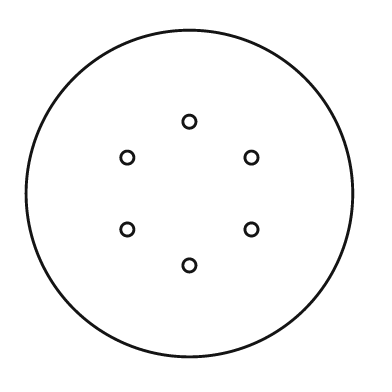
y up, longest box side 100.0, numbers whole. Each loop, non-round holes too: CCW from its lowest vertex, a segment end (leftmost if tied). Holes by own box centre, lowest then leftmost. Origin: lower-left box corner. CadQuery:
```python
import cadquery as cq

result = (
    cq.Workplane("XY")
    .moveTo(50.0, 50.0)
    .circle(50.0)
    .moveTo(50.0, 28.0)
    .circle(2.0)
    .moveTo(31.0, 39.0)
    .circle(2.0)
    .moveTo(69.0, 39.0)
    .circle(2.0)
    .moveTo(31.0, 61.0)
    .circle(2.0)
    .moveTo(69.0, 61.0)
    .circle(2.0)
    .moveTo(50.0, 72.0)
    .circle(2.0)
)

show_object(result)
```